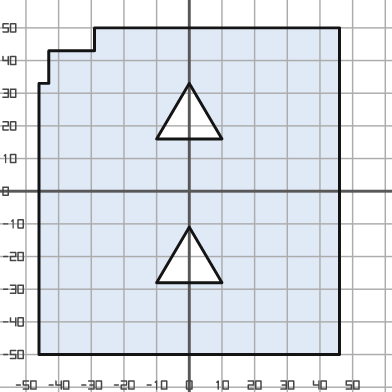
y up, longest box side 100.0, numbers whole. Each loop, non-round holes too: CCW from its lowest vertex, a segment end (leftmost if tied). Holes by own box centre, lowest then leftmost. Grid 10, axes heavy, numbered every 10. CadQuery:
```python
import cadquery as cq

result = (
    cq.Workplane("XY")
    .moveTo(-46.0, -50.0)
    .lineTo(46.0, -50.0)
    .lineTo(46.0, 50.0)
    .lineTo(-29.0, 50.0)
    .lineTo(-29.0, 43.0)
    .lineTo(-43.0, 43.0)
    .lineTo(-43.0, 33.0)
    .lineTo(-46.0, 33.0)
    .close()
    .moveTo(-10.0, -28.0)
    .lineTo(10.0, -28.0)
    .lineTo(0.0, -11.0)
    .close()
    .moveTo(-10.0, 16.0)
    .lineTo(10.0, 16.0)
    .lineTo(0.0, 33.0)
    .close()
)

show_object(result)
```